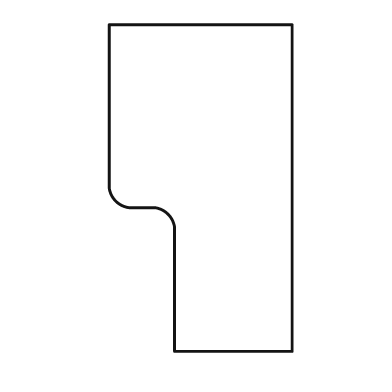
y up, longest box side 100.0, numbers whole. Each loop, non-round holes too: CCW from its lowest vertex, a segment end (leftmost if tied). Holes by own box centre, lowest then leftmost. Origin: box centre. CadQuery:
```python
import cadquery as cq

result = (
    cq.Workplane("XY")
    .moveTo(-8.0, -50.0)
    .lineTo(28.0, -50.0)
    .lineTo(28.0, 50.0)
    .lineTo(-28.0, 50.0)
    .lineTo(-28.0, 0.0)
    .threePointArc((-26.0, -4.0), (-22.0, -6.0))
    .lineTo(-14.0, -6.0)
    .threePointArc((-10.0, -8.0), (-8.0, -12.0))
    .close()
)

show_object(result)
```